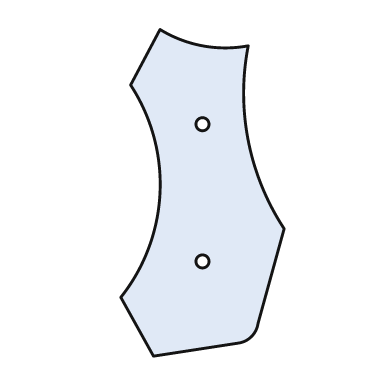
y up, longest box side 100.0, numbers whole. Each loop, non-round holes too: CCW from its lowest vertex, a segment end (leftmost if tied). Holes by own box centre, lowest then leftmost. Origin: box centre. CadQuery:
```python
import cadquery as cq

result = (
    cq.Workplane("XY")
    .moveTo(-15.0, -50.0)
    .lineTo(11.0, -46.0)
    .threePointArc((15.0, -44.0), (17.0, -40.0))
    .lineTo(25.0, -11.0)
    .threePointArc((14.0, 16.0), (14.0, 45.0))
    .threePointArc((0.0, 45.0), (-13.0, 50.0))
    .lineTo(-22.0, 33.0)
    .threePointArc((-13.0, 0.0), (-25.0, -32.0))
    .close()
    .moveTo(0.0, -21.0)
    .circle(2.0)
    .moveTo(0.0, 21.0)
    .circle(2.0)
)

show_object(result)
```